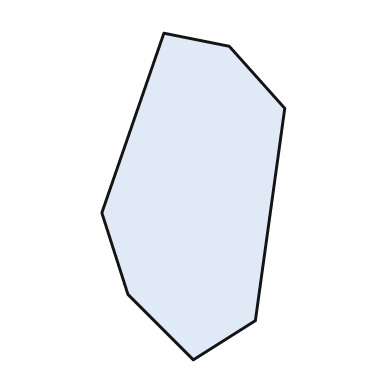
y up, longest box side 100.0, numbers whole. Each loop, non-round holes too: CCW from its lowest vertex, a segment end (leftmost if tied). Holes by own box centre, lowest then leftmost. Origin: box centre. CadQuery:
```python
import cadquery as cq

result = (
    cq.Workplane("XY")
    .moveTo(0.0, -50.0)
    .lineTo(19.0, -38.0)
    .lineTo(28.0, 27.0)
    .lineTo(11.0, 46.0)
    .lineTo(-9.0, 50.0)
    .lineTo(-28.0, -5.0)
    .lineTo(-20.0, -30.0)
    .close()
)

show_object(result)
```